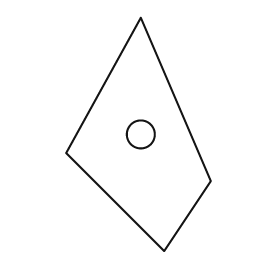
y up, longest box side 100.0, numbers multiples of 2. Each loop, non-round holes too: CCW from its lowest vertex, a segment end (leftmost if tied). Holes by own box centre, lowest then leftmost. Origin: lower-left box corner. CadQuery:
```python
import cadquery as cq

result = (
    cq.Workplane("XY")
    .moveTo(42.0, 0.0)
    .lineTo(62.0, 30.0)
    .lineTo(32.0, 100.0)
    .lineTo(0.0, 42.0)
    .close()
    .moveTo(32.0, 50.0)
    .circle(6.0)
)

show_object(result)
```